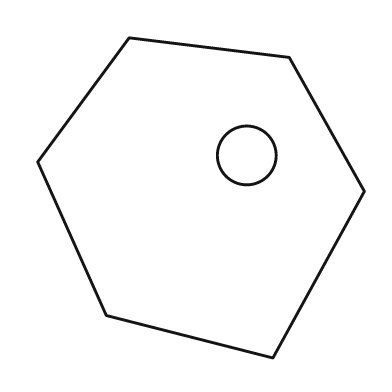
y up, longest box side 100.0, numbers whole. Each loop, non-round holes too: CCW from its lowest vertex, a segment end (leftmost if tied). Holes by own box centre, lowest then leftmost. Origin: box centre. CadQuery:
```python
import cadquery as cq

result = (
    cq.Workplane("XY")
    .moveTo(22.0, -49.0)
    .lineTo(50.0, 2.0)
    .lineTo(27.0, 43.0)
    .lineTo(-22.0, 49.0)
    .lineTo(-50.0, 11.0)
    .lineTo(-29.0, -36.0)
    .close()
    .moveTo(14.0, 13.0)
    .circle(9.0)
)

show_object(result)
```